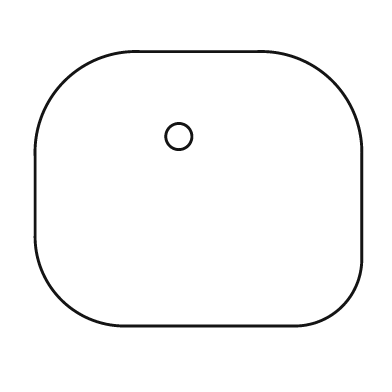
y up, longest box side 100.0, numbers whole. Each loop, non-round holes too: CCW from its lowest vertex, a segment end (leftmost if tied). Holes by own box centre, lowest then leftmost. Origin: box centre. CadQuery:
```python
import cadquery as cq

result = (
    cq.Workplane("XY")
    .moveTo(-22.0, -42.0)
    .lineTo(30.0, -42.0)
    .threePointArc((44.0, -36.0), (50.0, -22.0))
    .lineTo(50.0, 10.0)
    .threePointArc((41.0, 33.0), (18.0, 42.0))
    .lineTo(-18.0, 42.0)
    .threePointArc((-41.0, 33.0), (-50.0, 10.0))
    .lineTo(-50.0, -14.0)
    .threePointArc((-42.0, -34.0), (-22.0, -42.0))
    .close()
    .moveTo(-6.0, 16.0)
    .circle(4.0)
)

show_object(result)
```